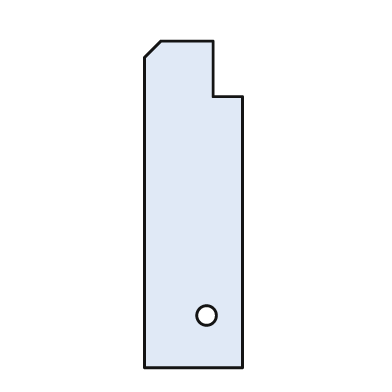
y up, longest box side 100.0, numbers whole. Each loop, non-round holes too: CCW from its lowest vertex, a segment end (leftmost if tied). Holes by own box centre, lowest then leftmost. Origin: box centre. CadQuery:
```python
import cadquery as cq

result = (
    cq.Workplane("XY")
    .moveTo(-15.0, -50.0)
    .lineTo(15.0, -50.0)
    .lineTo(15.0, 33.0)
    .lineTo(6.0, 33.0)
    .lineTo(6.0, 50.0)
    .lineTo(-10.0, 50.0)
    .lineTo(-15.0, 45.0)
    .close()
    .moveTo(4.0, -34.0)
    .circle(3.0)
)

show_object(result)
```